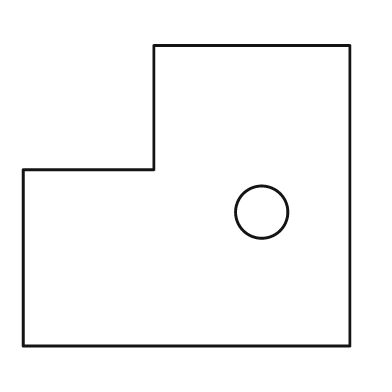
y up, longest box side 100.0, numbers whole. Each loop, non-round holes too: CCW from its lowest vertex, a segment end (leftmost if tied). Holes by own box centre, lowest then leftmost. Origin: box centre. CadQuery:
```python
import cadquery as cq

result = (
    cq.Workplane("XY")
    .moveTo(-50.0, -46.0)
    .lineTo(50.0, -46.0)
    .lineTo(50.0, 46.0)
    .lineTo(-10.0, 46.0)
    .lineTo(-10.0, 8.0)
    .lineTo(-50.0, 8.0)
    .close()
    .moveTo(23.0, -5.0)
    .circle(8.0)
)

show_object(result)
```